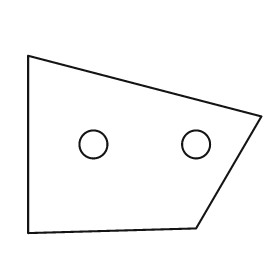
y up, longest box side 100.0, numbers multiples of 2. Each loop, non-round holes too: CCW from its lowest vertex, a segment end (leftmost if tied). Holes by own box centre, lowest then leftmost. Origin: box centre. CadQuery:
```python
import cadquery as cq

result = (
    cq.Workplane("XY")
    .moveTo(-50.0, -38.0)
    .lineTo(22.0, -36.0)
    .lineTo(50.0, 12.0)
    .lineTo(-50.0, 38.0)
    .close()
    .moveTo(-22.0, 0.0)
    .circle(6.0)
    .moveTo(22.0, 0.0)
    .circle(6.0)
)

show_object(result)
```